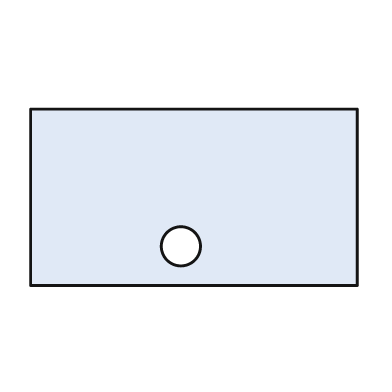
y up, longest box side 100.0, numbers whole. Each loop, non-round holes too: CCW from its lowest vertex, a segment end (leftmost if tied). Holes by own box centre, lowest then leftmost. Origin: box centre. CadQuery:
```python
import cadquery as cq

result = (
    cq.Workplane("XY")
    .moveTo(-50.0, -27.0)
    .lineTo(50.0, -27.0)
    .lineTo(50.0, 27.0)
    .lineTo(-50.0, 27.0)
    .close()
    .moveTo(-4.0, -15.0)
    .circle(6.0)
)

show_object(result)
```